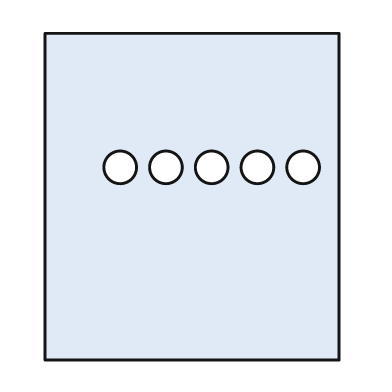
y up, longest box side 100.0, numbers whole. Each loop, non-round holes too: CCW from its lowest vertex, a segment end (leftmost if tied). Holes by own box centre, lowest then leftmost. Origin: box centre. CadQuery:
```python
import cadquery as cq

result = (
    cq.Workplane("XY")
    .moveTo(-45.0, -50.0)
    .lineTo(45.0, -50.0)
    .lineTo(45.0, 50.0)
    .lineTo(-45.0, 50.0)
    .close()
    .moveTo(-22.0, 9.0)
    .circle(5.0)
    .moveTo(-8.0, 9.0)
    .circle(5.0)
    .moveTo(6.0, 9.0)
    .circle(5.0)
    .moveTo(20.0, 9.0)
    .circle(5.0)
    .moveTo(34.0, 9.0)
    .circle(5.0)
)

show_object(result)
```